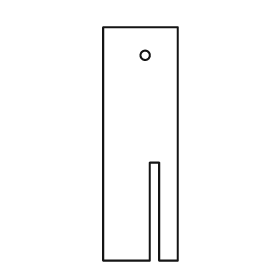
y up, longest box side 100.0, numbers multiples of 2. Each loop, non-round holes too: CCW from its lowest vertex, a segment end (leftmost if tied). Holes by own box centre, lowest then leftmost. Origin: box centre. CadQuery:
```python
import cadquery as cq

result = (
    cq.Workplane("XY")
    .moveTo(-16.0, -50.0)
    .lineTo(4.0, -50.0)
    .lineTo(4.0, -8.0)
    .lineTo(8.0, -8.0)
    .lineTo(8.0, -50.0)
    .lineTo(16.0, -50.0)
    .lineTo(16.0, 50.0)
    .lineTo(-16.0, 50.0)
    .close()
    .moveTo(2.0, 38.0)
    .circle(2.0)
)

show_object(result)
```